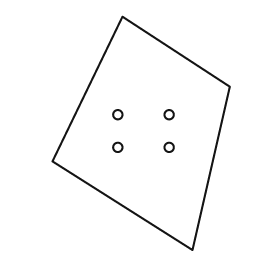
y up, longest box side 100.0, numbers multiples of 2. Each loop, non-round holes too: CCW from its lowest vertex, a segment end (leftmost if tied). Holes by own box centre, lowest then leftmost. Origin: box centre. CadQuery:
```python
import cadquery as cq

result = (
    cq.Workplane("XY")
    .moveTo(22.0, -50.0)
    .lineTo(38.0, 20.0)
    .lineTo(-8.0, 50.0)
    .lineTo(-38.0, -12.0)
    .close()
    .moveTo(-10.0, -6.0)
    .circle(2.0)
    .moveTo(12.0, -6.0)
    .circle(2.0)
    .moveTo(-10.0, 8.0)
    .circle(2.0)
    .moveTo(12.0, 8.0)
    .circle(2.0)
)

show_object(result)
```